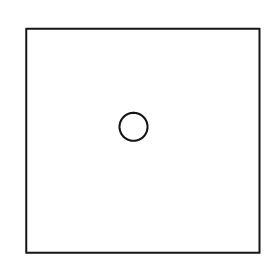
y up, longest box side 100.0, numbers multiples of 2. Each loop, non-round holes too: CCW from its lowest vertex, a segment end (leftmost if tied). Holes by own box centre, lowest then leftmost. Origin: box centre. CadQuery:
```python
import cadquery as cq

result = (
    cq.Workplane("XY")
    .moveTo(-50.0, -48.0)
    .lineTo(50.0, -48.0)
    .lineTo(50.0, 48.0)
    .lineTo(-50.0, 48.0)
    .close()
    .moveTo(-4.0, 6.0)
    .circle(6.0)
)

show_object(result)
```